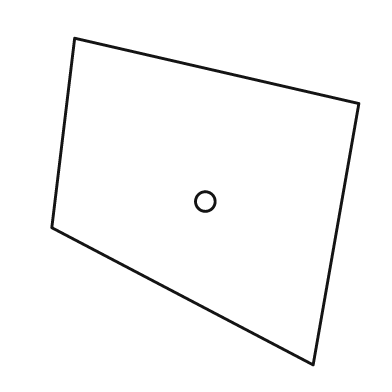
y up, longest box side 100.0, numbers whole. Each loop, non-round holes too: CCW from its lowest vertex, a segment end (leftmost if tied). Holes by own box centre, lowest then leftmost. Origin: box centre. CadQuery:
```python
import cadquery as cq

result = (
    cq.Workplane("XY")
    .moveTo(33.0, -50.0)
    .lineTo(47.0, 30.0)
    .lineTo(-40.0, 50.0)
    .lineTo(-47.0, -8.0)
    .close()
    .moveTo(0.0, 0.0)
    .circle(3.0)
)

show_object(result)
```